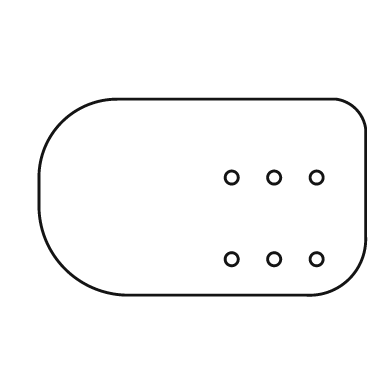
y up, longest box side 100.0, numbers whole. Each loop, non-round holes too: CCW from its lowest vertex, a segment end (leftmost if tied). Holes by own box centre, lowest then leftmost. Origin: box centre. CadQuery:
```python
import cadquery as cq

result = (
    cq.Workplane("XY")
    .moveTo(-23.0, -30.0)
    .lineTo(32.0, -30.0)
    .threePointArc((45.0, -25.0), (50.0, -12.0))
    .lineTo(50.0, 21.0)
    .threePointArc((47.0, 27.0), (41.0, 30.0))
    .lineTo(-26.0, 30.0)
    .threePointArc((-43.0, 23.0), (-50.0, 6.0))
    .lineTo(-50.0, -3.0)
    .threePointArc((-42.0, -22.0), (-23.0, -30.0))
    .close()
    .moveTo(9.0, -19.0)
    .circle(2.0)
    .moveTo(22.0, -19.0)
    .circle(2.0)
    .moveTo(35.0, -19.0)
    .circle(2.0)
    .moveTo(9.0, 6.0)
    .circle(2.0)
    .moveTo(22.0, 6.0)
    .circle(2.0)
    .moveTo(35.0, 6.0)
    .circle(2.0)
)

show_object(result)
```